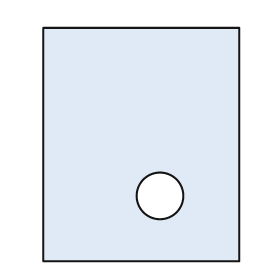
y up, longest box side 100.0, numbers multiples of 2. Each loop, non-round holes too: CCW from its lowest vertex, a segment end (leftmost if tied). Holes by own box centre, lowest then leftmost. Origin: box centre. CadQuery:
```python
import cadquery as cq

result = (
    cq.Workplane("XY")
    .moveTo(-42.0, -50.0)
    .lineTo(42.0, -50.0)
    .lineTo(42.0, 50.0)
    .lineTo(-42.0, 50.0)
    .close()
    .moveTo(8.0, -22.0)
    .circle(10.0)
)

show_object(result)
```